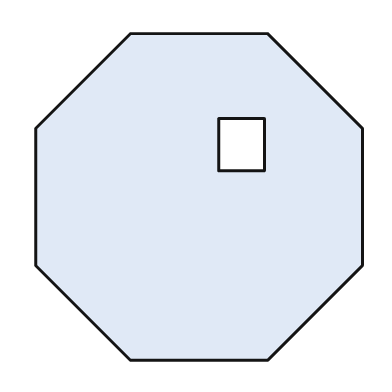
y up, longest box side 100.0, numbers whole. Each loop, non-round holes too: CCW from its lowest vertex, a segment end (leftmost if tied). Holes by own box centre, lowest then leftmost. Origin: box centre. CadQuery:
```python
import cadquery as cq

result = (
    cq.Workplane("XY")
    .moveTo(-21.0, -50.0)
    .lineTo(21.0, -50.0)
    .lineTo(50.0, -21.0)
    .lineTo(50.0, 21.0)
    .lineTo(21.0, 50.0)
    .lineTo(-21.0, 50.0)
    .lineTo(-50.0, 21.0)
    .lineTo(-50.0, -21.0)
    .close()
    .moveTo(6.0, 8.0)
    .lineTo(20.0, 8.0)
    .lineTo(20.0, 24.0)
    .lineTo(6.0, 24.0)
    .close()
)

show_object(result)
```